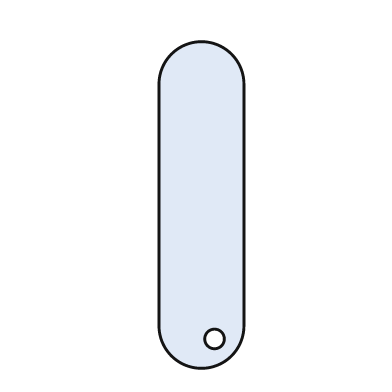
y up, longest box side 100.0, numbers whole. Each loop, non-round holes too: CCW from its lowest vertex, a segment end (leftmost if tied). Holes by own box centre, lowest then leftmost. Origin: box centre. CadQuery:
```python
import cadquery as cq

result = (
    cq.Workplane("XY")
    .moveTo(-13.0, -37.0)
    .threePointArc((0.0, -50.0), (13.0, -37.0))
    .lineTo(13.0, 37.0)
    .threePointArc((0.0, 50.0), (-13.0, 37.0))
    .close()
    .moveTo(4.0, -41.0)
    .circle(3.0)
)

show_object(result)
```